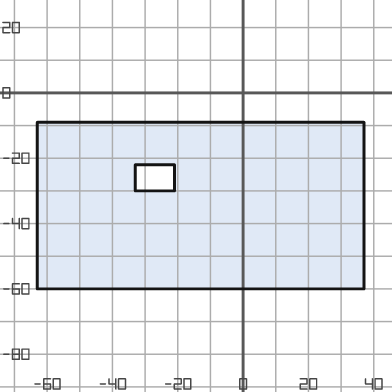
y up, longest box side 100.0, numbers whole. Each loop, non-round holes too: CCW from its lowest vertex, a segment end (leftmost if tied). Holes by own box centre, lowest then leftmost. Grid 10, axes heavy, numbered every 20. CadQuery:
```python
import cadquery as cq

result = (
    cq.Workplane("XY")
    .moveTo(-63.0, -60.0)
    .lineTo(37.0, -60.0)
    .lineTo(37.0, -9.0)
    .lineTo(-63.0, -9.0)
    .close()
    .moveTo(-33.0, -30.0)
    .lineTo(-21.0, -30.0)
    .lineTo(-21.0, -22.0)
    .lineTo(-33.0, -22.0)
    .close()
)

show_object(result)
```